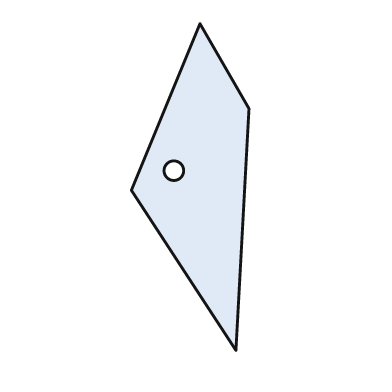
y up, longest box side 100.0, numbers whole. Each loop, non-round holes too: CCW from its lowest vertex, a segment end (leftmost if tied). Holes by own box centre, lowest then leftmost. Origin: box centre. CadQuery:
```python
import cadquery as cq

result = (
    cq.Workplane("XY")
    .moveTo(14.0, -50.0)
    .lineTo(18.0, 24.0)
    .lineTo(3.0, 50.0)
    .lineTo(-18.0, -1.0)
    .close()
    .moveTo(-5.0, 5.0)
    .circle(3.0)
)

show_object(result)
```